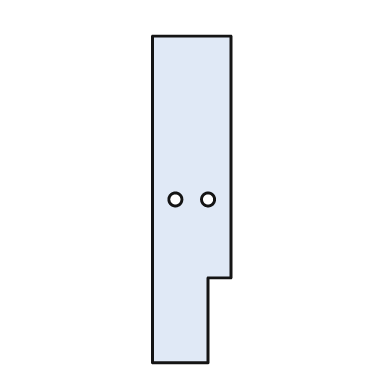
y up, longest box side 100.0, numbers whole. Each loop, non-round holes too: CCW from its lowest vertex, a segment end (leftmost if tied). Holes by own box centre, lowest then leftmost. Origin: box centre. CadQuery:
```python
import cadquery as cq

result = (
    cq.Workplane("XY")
    .moveTo(-12.0, -50.0)
    .lineTo(5.0, -50.0)
    .lineTo(5.0, -24.0)
    .lineTo(12.0, -24.0)
    .lineTo(12.0, 50.0)
    .lineTo(-12.0, 50.0)
    .close()
    .moveTo(-5.0, 0.0)
    .circle(2.0)
    .moveTo(5.0, 0.0)
    .circle(2.0)
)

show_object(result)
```